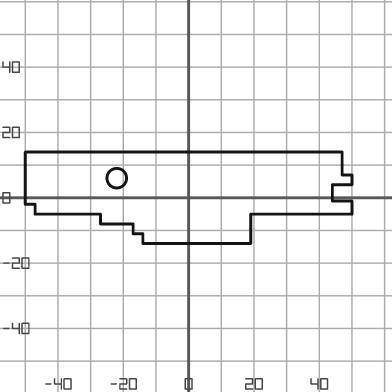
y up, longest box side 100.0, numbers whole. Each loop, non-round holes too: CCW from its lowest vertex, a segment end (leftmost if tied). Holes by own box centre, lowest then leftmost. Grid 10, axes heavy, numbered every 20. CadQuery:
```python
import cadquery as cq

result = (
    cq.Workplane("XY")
    .moveTo(-14.0, -14.0)
    .lineTo(19.0, -14.0)
    .lineTo(19.0, -5.0)
    .lineTo(50.0, -5.0)
    .lineTo(50.0, -1.0)
    .lineTo(44.0, -1.0)
    .lineTo(44.0, 4.0)
    .lineTo(50.0, 4.0)
    .lineTo(50.0, 7.0)
    .lineTo(47.0, 7.0)
    .lineTo(47.0, 14.0)
    .lineTo(-50.0, 14.0)
    .lineTo(-50.0, -2.0)
    .lineTo(-47.0, -2.0)
    .lineTo(-47.0, -5.0)
    .lineTo(-27.0, -5.0)
    .lineTo(-27.0, -8.0)
    .lineTo(-17.0, -8.0)
    .lineTo(-17.0, -11.0)
    .lineTo(-14.0, -11.0)
    .close()
    .moveTo(-22.0, 6.0)
    .circle(3.0)
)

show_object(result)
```